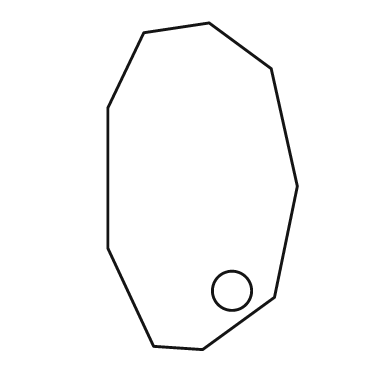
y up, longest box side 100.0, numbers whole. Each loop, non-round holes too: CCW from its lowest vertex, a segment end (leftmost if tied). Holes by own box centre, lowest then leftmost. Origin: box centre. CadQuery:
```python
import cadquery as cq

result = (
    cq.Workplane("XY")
    .moveTo(0.0, -50.0)
    .lineTo(22.0, -34.0)
    .lineTo(29.0, 0.0)
    .lineTo(21.0, 36.0)
    .lineTo(2.0, 50.0)
    .lineTo(-18.0, 47.0)
    .lineTo(-29.0, 24.0)
    .lineTo(-29.0, -19.0)
    .lineTo(-15.0, -49.0)
    .close()
    .moveTo(9.0, -32.0)
    .circle(6.0)
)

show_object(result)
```